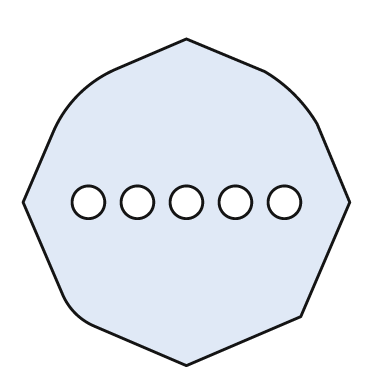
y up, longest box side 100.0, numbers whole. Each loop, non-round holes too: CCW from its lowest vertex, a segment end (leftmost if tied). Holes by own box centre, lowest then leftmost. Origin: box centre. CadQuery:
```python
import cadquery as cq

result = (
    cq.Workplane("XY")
    .moveTo(0.0, -50.0)
    .lineTo(35.0, -35.0)
    .lineTo(50.0, 0.0)
    .lineTo(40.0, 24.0)
    .threePointArc((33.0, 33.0), (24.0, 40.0))
    .lineTo(0.0, 50.0)
    .lineTo(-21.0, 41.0)
    .threePointArc((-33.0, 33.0), (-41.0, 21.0))
    .lineTo(-50.0, 0.0)
    .lineTo(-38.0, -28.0)
    .threePointArc((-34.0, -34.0), (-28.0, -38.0))
    .close()
    .moveTo(-30.0, 0.0)
    .circle(5.0)
    .moveTo(-15.0, 0.0)
    .circle(5.0)
    .moveTo(0.0, 0.0)
    .circle(5.0)
    .moveTo(15.0, 0.0)
    .circle(5.0)
    .moveTo(30.0, 0.0)
    .circle(5.0)
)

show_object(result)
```